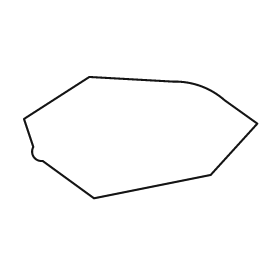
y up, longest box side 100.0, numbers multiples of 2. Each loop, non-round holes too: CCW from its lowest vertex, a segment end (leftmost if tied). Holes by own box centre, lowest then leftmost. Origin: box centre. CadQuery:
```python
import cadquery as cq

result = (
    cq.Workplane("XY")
    .moveTo(-20.0, -26.0)
    .lineTo(30.0, -16.0)
    .lineTo(50.0, 6.0)
    .lineTo(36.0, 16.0)
    .threePointArc((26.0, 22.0), (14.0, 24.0))
    .lineTo(-22.0, 26.0)
    .lineTo(-50.0, 8.0)
    .lineTo(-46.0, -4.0)
    .threePointArc((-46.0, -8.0), (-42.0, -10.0))
    .close()
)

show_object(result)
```